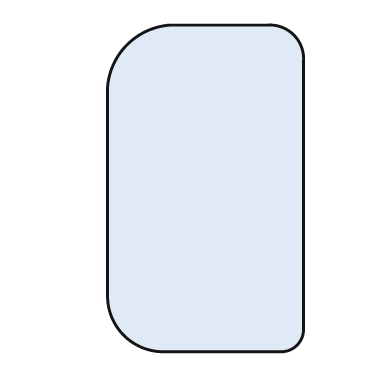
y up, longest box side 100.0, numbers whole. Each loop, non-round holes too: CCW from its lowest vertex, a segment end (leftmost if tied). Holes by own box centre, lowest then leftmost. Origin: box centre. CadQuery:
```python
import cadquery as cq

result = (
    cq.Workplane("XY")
    .moveTo(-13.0, -50.0)
    .lineTo(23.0, -50.0)
    .threePointArc((28.0, -48.0), (30.0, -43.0))
    .lineTo(30.0, 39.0)
    .threePointArc((27.0, 47.0), (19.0, 50.0))
    .lineTo(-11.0, 50.0)
    .threePointArc((-24.0, 44.0), (-30.0, 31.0))
    .lineTo(-30.0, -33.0)
    .threePointArc((-25.0, -45.0), (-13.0, -50.0))
    .close()
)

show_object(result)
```